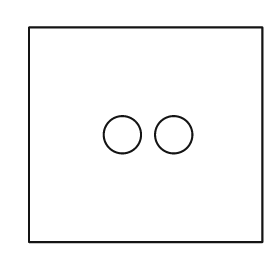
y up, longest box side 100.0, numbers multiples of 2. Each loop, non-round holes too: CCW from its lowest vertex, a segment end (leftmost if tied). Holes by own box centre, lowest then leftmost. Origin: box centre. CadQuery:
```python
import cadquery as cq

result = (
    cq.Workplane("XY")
    .moveTo(-50.0, -46.0)
    .lineTo(50.0, -46.0)
    .lineTo(50.0, 46.0)
    .lineTo(-50.0, 46.0)
    .close()
    .moveTo(-10.0, 0.0)
    .circle(8.0)
    .moveTo(12.0, 0.0)
    .circle(8.0)
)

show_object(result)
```